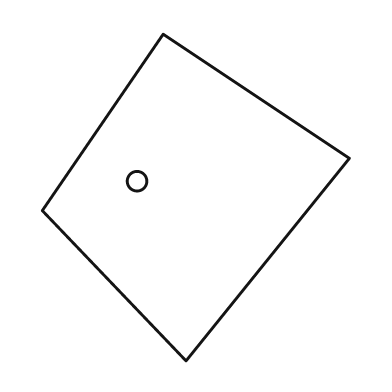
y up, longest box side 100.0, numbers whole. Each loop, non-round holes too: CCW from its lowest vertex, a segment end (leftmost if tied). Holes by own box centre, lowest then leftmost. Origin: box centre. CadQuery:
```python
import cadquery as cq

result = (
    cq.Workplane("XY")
    .moveTo(-3.0, -50.0)
    .lineTo(47.0, 12.0)
    .lineTo(-10.0, 50.0)
    .lineTo(-47.0, -4.0)
    .close()
    .moveTo(-18.0, 5.0)
    .circle(3.0)
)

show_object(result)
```